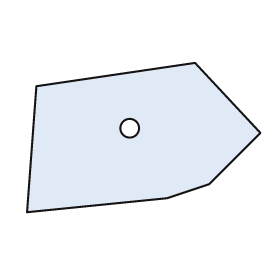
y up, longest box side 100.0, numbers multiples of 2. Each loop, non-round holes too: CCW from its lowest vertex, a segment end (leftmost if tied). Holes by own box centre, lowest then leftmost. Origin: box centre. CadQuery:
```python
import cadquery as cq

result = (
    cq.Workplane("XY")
    .moveTo(-50.0, -32.0)
    .lineTo(10.0, -26.0)
    .lineTo(28.0, -20.0)
    .lineTo(50.0, 2.0)
    .lineTo(22.0, 32.0)
    .lineTo(-46.0, 22.0)
    .close()
    .moveTo(-6.0, 4.0)
    .circle(4.0)
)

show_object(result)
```